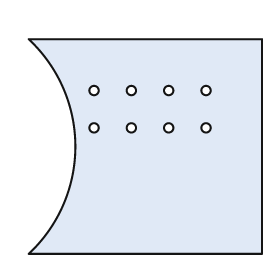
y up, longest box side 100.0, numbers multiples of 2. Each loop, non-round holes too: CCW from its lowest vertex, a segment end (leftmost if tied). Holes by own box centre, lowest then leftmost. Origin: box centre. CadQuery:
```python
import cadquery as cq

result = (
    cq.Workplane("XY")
    .moveTo(-50.0, -46.0)
    .lineTo(50.0, -46.0)
    .lineTo(50.0, 46.0)
    .lineTo(-50.0, 46.0)
    .threePointArc((-30.0, 0.0), (-50.0, -46.0))
    .close()
    .moveTo(-22.0, 8.0)
    .circle(2.0)
    .moveTo(-6.0, 8.0)
    .circle(2.0)
    .moveTo(10.0, 8.0)
    .circle(2.0)
    .moveTo(26.0, 8.0)
    .circle(2.0)
    .moveTo(-22.0, 24.0)
    .circle(2.0)
    .moveTo(-6.0, 24.0)
    .circle(2.0)
    .moveTo(10.0, 24.0)
    .circle(2.0)
    .moveTo(26.0, 24.0)
    .circle(2.0)
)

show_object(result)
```